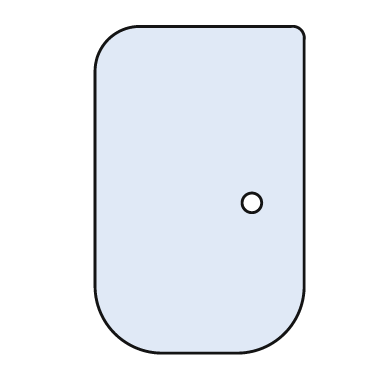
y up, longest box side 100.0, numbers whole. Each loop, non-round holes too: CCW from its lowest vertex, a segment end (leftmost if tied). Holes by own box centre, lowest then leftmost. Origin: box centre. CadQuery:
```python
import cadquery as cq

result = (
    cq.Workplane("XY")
    .moveTo(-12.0, -50.0)
    .lineTo(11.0, -50.0)
    .threePointArc((26.0, -44.0), (32.0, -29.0))
    .lineTo(32.0, 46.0)
    .threePointArc((31.0, 49.0), (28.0, 50.0))
    .lineTo(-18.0, 50.0)
    .threePointArc((-28.0, 46.0), (-32.0, 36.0))
    .lineTo(-32.0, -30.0)
    .threePointArc((-26.0, -44.0), (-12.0, -50.0))
    .close()
    .moveTo(16.0, -4.0)
    .circle(3.0)
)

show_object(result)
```